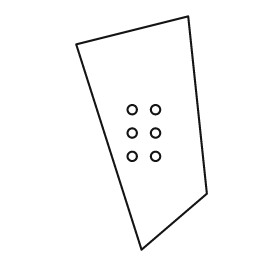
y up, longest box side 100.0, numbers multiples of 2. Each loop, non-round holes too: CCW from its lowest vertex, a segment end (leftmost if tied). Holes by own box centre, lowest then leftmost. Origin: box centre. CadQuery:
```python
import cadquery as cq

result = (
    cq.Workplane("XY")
    .moveTo(0.0, -50.0)
    .lineTo(28.0, -26.0)
    .lineTo(20.0, 50.0)
    .lineTo(-28.0, 38.0)
    .close()
    .moveTo(-4.0, -10.0)
    .circle(2.0)
    .moveTo(6.0, -10.0)
    .circle(2.0)
    .moveTo(-4.0, 0.0)
    .circle(2.0)
    .moveTo(6.0, 0.0)
    .circle(2.0)
    .moveTo(-4.0, 10.0)
    .circle(2.0)
    .moveTo(6.0, 10.0)
    .circle(2.0)
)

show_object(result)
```